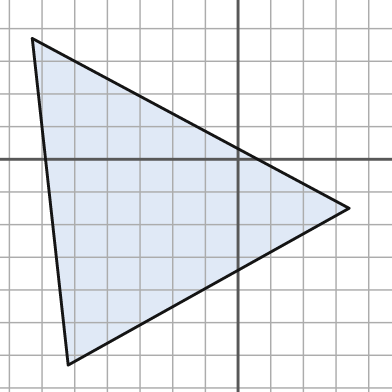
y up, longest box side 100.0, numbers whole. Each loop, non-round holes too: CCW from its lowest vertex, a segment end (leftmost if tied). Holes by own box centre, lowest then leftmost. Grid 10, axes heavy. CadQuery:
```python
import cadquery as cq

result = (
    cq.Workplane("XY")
    .moveTo(-52.0, -63.0)
    .lineTo(34.0, -15.0)
    .lineTo(-63.0, 37.0)
    .close()
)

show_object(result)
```